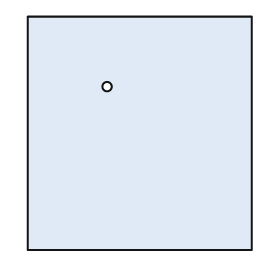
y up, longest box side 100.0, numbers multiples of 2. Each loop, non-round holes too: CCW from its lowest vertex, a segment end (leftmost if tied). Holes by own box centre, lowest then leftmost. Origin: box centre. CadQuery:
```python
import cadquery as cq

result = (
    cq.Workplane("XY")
    .moveTo(-48.0, -50.0)
    .lineTo(48.0, -50.0)
    .lineTo(48.0, 50.0)
    .lineTo(-48.0, 50.0)
    .close()
    .moveTo(-14.0, 20.0)
    .circle(2.0)
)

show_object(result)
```